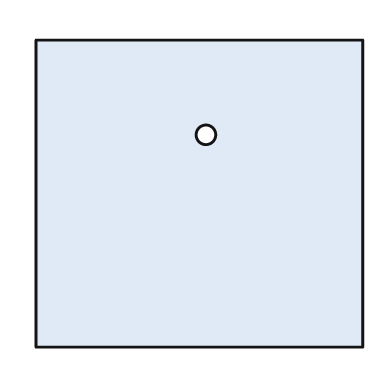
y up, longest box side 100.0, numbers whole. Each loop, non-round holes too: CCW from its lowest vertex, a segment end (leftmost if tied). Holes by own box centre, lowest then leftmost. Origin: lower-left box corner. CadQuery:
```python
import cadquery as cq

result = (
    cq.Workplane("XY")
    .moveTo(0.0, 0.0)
    .lineTo(100.0, 0.0)
    .lineTo(100.0, 94.0)
    .lineTo(0.0, 94.0)
    .close()
    .moveTo(52.0, 65.0)
    .circle(3.0)
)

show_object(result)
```